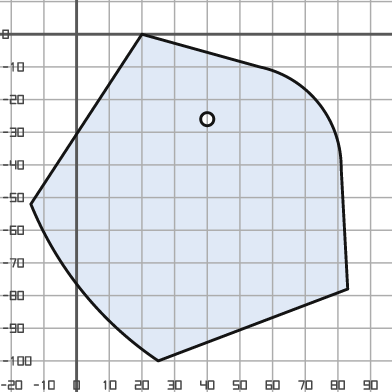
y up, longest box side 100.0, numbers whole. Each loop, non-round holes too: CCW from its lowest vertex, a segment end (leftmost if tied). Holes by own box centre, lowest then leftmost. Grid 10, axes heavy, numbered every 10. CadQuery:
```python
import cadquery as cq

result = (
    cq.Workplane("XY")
    .moveTo(25.0, -100.0)
    .lineTo(83.0, -78.0)
    .lineTo(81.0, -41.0)
    .threePointArc((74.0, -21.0), (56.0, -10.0))
    .lineTo(20.0, 0.0)
    .lineTo(-14.0, -52.0)
    .threePointArc((2.0, -79.0), (25.0, -100.0))
    .close()
    .moveTo(40.0, -26.0)
    .circle(2.0)
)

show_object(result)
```